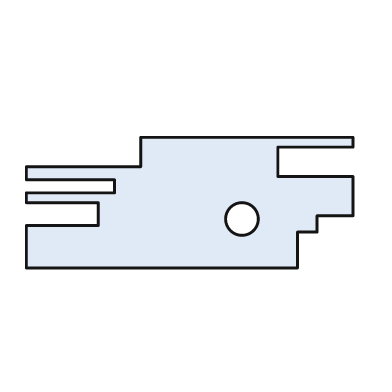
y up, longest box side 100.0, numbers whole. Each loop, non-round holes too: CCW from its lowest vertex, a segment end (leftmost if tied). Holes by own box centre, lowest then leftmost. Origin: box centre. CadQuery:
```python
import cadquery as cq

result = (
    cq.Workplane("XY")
    .moveTo(-50.0, -20.0)
    .lineTo(33.0, -20.0)
    .lineTo(33.0, -9.0)
    .lineTo(39.0, -9.0)
    .lineTo(39.0, -4.0)
    .lineTo(50.0, -4.0)
    .lineTo(50.0, 8.0)
    .lineTo(27.0, 8.0)
    .lineTo(27.0, 17.0)
    .lineTo(50.0, 17.0)
    .lineTo(50.0, 20.0)
    .lineTo(-15.0, 20.0)
    .lineTo(-15.0, 11.0)
    .lineTo(-50.0, 11.0)
    .lineTo(-50.0, 7.0)
    .lineTo(-23.0, 7.0)
    .lineTo(-23.0, 3.0)
    .lineTo(-50.0, 3.0)
    .lineTo(-50.0, 0.0)
    .lineTo(-28.0, 0.0)
    .lineTo(-28.0, -7.0)
    .lineTo(-50.0, -7.0)
    .close()
    .moveTo(16.0, -5.0)
    .circle(5.0)
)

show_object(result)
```